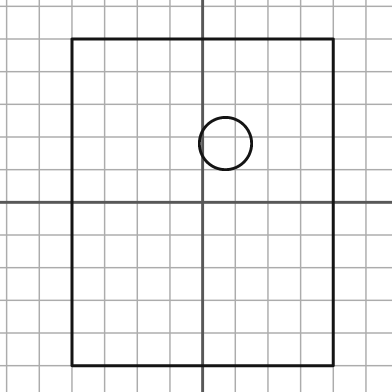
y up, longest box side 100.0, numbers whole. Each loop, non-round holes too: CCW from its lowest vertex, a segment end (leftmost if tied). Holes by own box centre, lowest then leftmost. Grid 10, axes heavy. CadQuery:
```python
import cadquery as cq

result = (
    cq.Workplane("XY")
    .moveTo(-40.0, -50.0)
    .lineTo(40.0, -50.0)
    .lineTo(40.0, 50.0)
    .lineTo(-40.0, 50.0)
    .close()
    .moveTo(7.0, 18.0)
    .circle(8.0)
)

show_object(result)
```